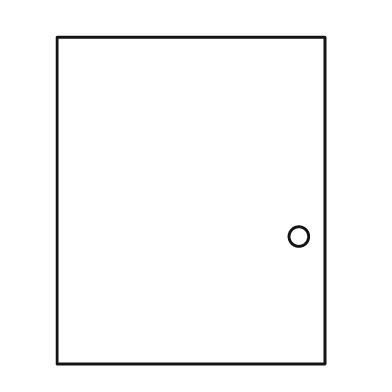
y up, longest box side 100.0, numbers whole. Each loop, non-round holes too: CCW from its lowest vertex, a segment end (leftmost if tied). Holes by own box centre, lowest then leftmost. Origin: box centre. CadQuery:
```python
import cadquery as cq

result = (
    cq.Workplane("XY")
    .moveTo(-41.0, -50.0)
    .lineTo(41.0, -50.0)
    .lineTo(41.0, 50.0)
    .lineTo(-41.0, 50.0)
    .close()
    .moveTo(33.0, -11.0)
    .circle(3.0)
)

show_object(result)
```